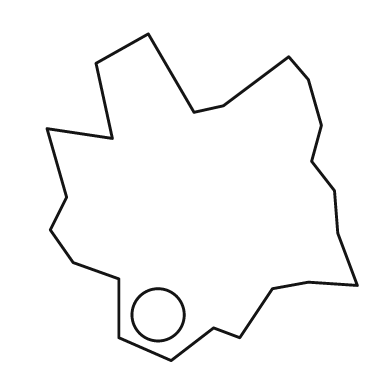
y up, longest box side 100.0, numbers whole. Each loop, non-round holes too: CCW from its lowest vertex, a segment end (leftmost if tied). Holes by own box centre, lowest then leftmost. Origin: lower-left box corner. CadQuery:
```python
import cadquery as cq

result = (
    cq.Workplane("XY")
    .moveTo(38.0, 0.0)
    .lineTo(51.0, 10.0)
    .lineTo(59.0, 7.0)
    .lineTo(69.0, 22.0)
    .lineTo(80.0, 24.0)
    .lineTo(95.0, 23.0)
    .lineTo(89.0, 39.0)
    .lineTo(88.0, 52.0)
    .lineTo(81.0, 61.0)
    .lineTo(84.0, 72.0)
    .lineTo(80.0, 86.0)
    .lineTo(74.0, 93.0)
    .lineTo(54.0, 78.0)
    .lineTo(45.0, 76.0)
    .lineTo(31.0, 100.0)
    .lineTo(15.0, 91.0)
    .lineTo(20.0, 68.0)
    .lineTo(0.0, 71.0)
    .lineTo(6.0, 50.0)
    .lineTo(1.0, 40.0)
    .lineTo(8.0, 30.0)
    .lineTo(22.0, 25.0)
    .lineTo(22.0, 7.0)
    .close()
    .moveTo(34.0, 14.0)
    .circle(8.0)
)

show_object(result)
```